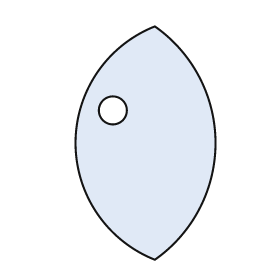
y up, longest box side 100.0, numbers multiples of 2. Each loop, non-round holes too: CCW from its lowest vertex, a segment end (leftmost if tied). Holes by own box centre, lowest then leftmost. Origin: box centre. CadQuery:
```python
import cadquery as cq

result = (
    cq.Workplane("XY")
    .moveTo(4.0, -50.0)
    .threePointArc((30.0, 0.0), (4.0, 50.0))
    .threePointArc((-30.0, 0.0), (4.0, -50.0))
    .close()
    .moveTo(-14.0, 14.0)
    .circle(6.0)
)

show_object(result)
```